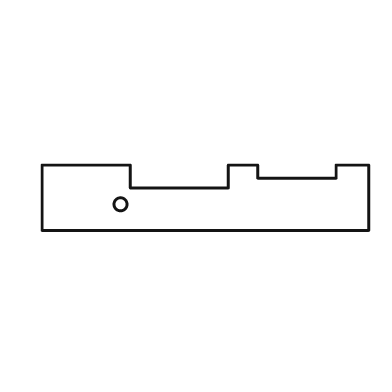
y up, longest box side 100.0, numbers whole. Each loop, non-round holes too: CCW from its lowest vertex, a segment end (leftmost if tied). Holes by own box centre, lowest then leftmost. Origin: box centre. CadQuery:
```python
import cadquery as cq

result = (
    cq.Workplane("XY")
    .moveTo(-50.0, -10.0)
    .lineTo(50.0, -10.0)
    .lineTo(50.0, 10.0)
    .lineTo(40.0, 10.0)
    .lineTo(40.0, 6.0)
    .lineTo(16.0, 6.0)
    .lineTo(16.0, 10.0)
    .lineTo(7.0, 10.0)
    .lineTo(7.0, 3.0)
    .lineTo(-23.0, 3.0)
    .lineTo(-23.0, 10.0)
    .lineTo(-50.0, 10.0)
    .close()
    .moveTo(-26.0, -2.0)
    .circle(2.0)
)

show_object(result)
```